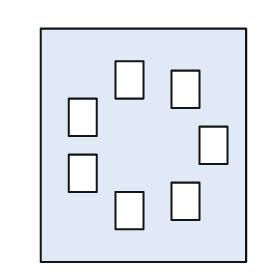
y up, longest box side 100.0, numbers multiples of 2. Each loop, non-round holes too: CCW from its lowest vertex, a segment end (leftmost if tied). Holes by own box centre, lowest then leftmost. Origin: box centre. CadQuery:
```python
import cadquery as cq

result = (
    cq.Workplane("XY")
    .moveTo(-44.0, -50.0)
    .lineTo(44.0, -50.0)
    .lineTo(44.0, 50.0)
    .lineTo(-44.0, 50.0)
    .close()
    .moveTo(-12.0, -36.0)
    .lineTo(0.0, -36.0)
    .lineTo(0.0, -20.0)
    .lineTo(-12.0, -20.0)
    .close()
    .moveTo(12.0, -32.0)
    .lineTo(24.0, -32.0)
    .lineTo(24.0, -16.0)
    .lineTo(12.0, -16.0)
    .close()
    .moveTo(-32.0, -20.0)
    .lineTo(-20.0, -20.0)
    .lineTo(-20.0, -4.0)
    .lineTo(-32.0, -4.0)
    .close()
    .moveTo(24.0, -8.0)
    .lineTo(36.0, -8.0)
    .lineTo(36.0, 8.0)
    .lineTo(24.0, 8.0)
    .close()
    .moveTo(-32.0, 4.0)
    .lineTo(-20.0, 4.0)
    .lineTo(-20.0, 20.0)
    .lineTo(-32.0, 20.0)
    .close()
    .moveTo(12.0, 16.0)
    .lineTo(24.0, 16.0)
    .lineTo(24.0, 32.0)
    .lineTo(12.0, 32.0)
    .close()
    .moveTo(-12.0, 20.0)
    .lineTo(0.0, 20.0)
    .lineTo(0.0, 36.0)
    .lineTo(-12.0, 36.0)
    .close()
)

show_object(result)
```